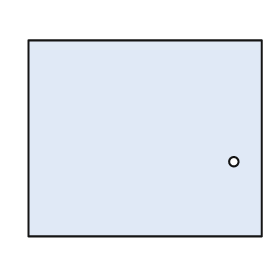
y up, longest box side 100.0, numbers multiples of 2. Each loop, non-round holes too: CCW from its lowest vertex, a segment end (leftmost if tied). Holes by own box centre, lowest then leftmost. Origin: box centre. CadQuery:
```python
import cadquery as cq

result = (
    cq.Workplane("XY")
    .moveTo(-50.0, -42.0)
    .lineTo(50.0, -42.0)
    .lineTo(50.0, 42.0)
    .lineTo(-50.0, 42.0)
    .close()
    .moveTo(38.0, -10.0)
    .circle(2.0)
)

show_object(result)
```